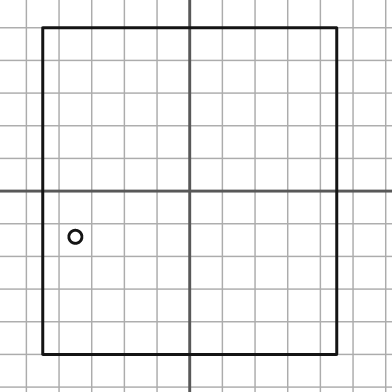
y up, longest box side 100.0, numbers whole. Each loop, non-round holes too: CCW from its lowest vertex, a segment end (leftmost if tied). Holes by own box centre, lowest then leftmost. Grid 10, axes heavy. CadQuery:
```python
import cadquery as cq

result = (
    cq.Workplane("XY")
    .moveTo(-45.0, -50.0)
    .lineTo(45.0, -50.0)
    .lineTo(45.0, 50.0)
    .lineTo(-45.0, 50.0)
    .close()
    .moveTo(-35.0, -14.0)
    .circle(2.0)
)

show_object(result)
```